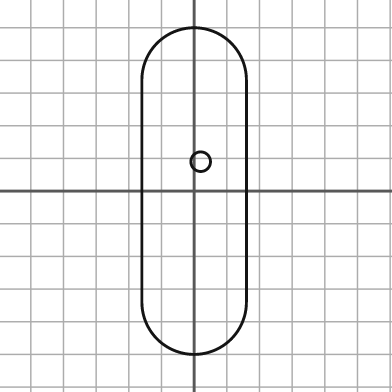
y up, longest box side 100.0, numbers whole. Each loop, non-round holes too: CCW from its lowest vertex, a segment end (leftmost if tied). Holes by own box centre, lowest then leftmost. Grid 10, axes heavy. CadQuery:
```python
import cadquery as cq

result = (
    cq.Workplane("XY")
    .moveTo(-16.0, -34.0)
    .threePointArc((0.0, -50.0), (16.0, -34.0))
    .lineTo(16.0, 34.0)
    .threePointArc((0.0, 50.0), (-16.0, 34.0))
    .close()
    .moveTo(2.0, 9.0)
    .circle(3.0)
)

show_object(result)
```